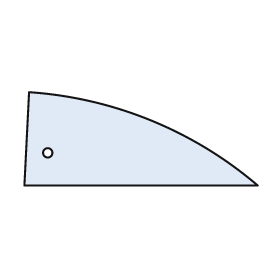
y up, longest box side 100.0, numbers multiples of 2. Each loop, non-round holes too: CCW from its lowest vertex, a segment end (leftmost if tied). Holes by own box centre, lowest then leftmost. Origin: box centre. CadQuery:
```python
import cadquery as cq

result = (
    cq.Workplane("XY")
    .moveTo(-50.0, -20.0)
    .lineTo(50.0, -20.0)
    .threePointArc((4.0, 8.0), (-48.0, 20.0))
    .close()
    .moveTo(-40.0, -6.0)
    .circle(2.0)
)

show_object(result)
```